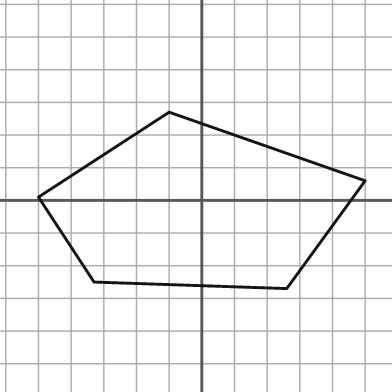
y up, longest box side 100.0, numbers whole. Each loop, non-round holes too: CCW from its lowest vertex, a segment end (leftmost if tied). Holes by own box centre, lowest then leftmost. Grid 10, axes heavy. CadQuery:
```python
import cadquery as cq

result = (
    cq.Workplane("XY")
    .moveTo(26.0, -27.0)
    .lineTo(50.0, 6.0)
    .lineTo(-10.0, 27.0)
    .lineTo(-50.0, 1.0)
    .lineTo(-33.0, -25.0)
    .close()
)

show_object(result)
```